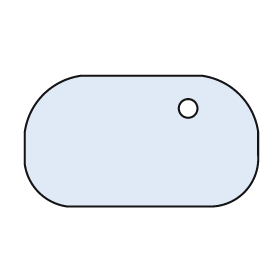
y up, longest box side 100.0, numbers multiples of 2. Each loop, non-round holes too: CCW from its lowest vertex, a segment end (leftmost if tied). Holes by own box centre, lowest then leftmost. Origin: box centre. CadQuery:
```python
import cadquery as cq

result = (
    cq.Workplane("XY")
    .moveTo(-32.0, -28.0)
    .lineTo(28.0, -28.0)
    .threePointArc((44.0, -22.0), (50.0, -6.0))
    .lineTo(50.0, 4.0)
    .threePointArc((42.0, 20.0), (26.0, 28.0))
    .lineTo(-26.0, 28.0)
    .threePointArc((-42.0, 20.0), (-50.0, 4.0))
    .lineTo(-50.0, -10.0)
    .threePointArc((-44.0, -22.0), (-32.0, -28.0))
    .close()
    .moveTo(20.0, 14.0)
    .circle(4.0)
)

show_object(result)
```